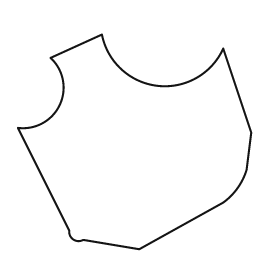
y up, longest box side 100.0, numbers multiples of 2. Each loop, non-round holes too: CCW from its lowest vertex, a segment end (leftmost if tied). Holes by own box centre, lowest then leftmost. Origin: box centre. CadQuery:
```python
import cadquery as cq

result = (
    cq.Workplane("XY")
    .moveTo(2.0, -46.0)
    .lineTo(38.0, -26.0)
    .threePointArc((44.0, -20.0), (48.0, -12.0))
    .lineTo(50.0, 4.0)
    .lineTo(38.0, 40.0)
    .threePointArc((10.0, 24.0), (-14.0, 46.0))
    .lineTo(-36.0, 36.0)
    .threePointArc((-32.0, 16.0), (-50.0, 6.0))
    .lineTo(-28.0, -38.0)
    .threePointArc((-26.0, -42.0), (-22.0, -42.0))
    .close()
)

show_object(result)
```